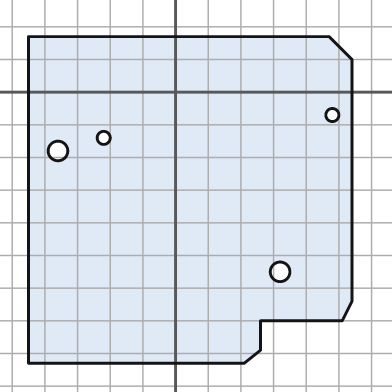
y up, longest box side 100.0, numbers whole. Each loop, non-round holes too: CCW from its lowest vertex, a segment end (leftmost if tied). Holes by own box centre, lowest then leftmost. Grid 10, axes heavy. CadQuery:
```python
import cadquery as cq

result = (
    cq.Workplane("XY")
    .moveTo(-45.0, -83.0)
    .lineTo(21.0, -83.0)
    .lineTo(26.0, -79.0)
    .lineTo(26.0, -70.0)
    .lineTo(51.0, -70.0)
    .lineTo(54.0, -64.0)
    .lineTo(54.0, 10.0)
    .lineTo(47.0, 17.0)
    .lineTo(-45.0, 17.0)
    .close()
    .moveTo(32.0, -55.0)
    .circle(3.0)
    .moveTo(-36.0, -18.0)
    .circle(3.0)
    .moveTo(-22.0, -14.0)
    .circle(2.0)
    .moveTo(48.0, -7.0)
    .circle(2.0)
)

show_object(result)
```